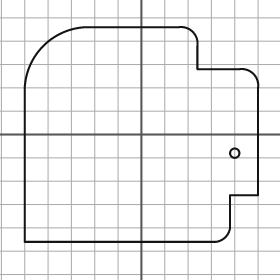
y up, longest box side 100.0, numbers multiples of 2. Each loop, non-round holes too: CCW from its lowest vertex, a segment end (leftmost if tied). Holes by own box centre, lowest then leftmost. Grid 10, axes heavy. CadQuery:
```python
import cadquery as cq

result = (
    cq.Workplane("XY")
    .moveTo(-50.0, -46.0)
    .lineTo(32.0, -46.0)
    .threePointArc((36.0, -44.0), (38.0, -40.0))
    .lineTo(38.0, -26.0)
    .lineTo(50.0, -26.0)
    .lineTo(50.0, 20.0)
    .threePointArc((48.0, 26.0), (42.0, 28.0))
    .lineTo(24.0, 28.0)
    .lineTo(24.0, 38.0)
    .threePointArc((22.0, 44.0), (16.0, 46.0))
    .lineTo(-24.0, 46.0)
    .threePointArc((-42.0, 38.0), (-50.0, 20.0))
    .close()
    .moveTo(40.0, -8.0)
    .circle(2.0)
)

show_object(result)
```